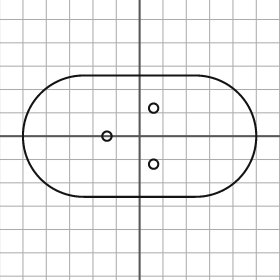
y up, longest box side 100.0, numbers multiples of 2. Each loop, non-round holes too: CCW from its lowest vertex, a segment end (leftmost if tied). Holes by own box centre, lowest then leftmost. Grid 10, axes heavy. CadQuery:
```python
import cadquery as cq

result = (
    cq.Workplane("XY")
    .moveTo(-24.0, -26.0)
    .lineTo(24.0, -26.0)
    .threePointArc((50.0, 0.0), (24.0, 26.0))
    .lineTo(-24.0, 26.0)
    .threePointArc((-50.0, 0.0), (-24.0, -26.0))
    .close()
    .moveTo(6.0, -12.0)
    .circle(2.0)
    .moveTo(-14.0, 0.0)
    .circle(2.0)
    .moveTo(6.0, 12.0)
    .circle(2.0)
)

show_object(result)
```